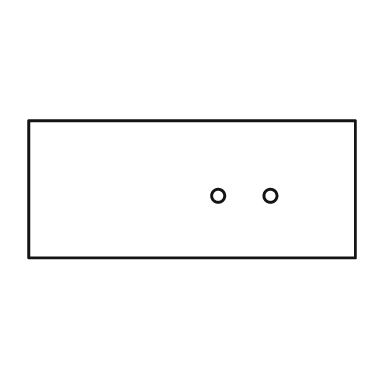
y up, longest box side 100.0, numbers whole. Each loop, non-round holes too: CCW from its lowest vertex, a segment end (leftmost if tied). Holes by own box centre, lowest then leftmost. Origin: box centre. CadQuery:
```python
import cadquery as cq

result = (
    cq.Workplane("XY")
    .moveTo(-50.0, -21.0)
    .lineTo(50.0, -21.0)
    .lineTo(50.0, 21.0)
    .lineTo(-50.0, 21.0)
    .close()
    .moveTo(8.0, -2.0)
    .circle(2.0)
    .moveTo(24.0, -2.0)
    .circle(2.0)
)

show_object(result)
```